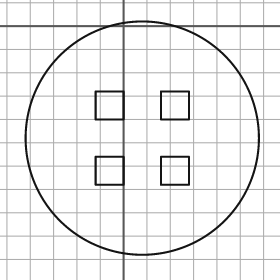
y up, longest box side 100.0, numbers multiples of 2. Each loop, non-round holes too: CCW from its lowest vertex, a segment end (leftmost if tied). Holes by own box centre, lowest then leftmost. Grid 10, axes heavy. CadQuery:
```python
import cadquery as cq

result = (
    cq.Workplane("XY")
    .moveTo(8.0, -48.0)
    .circle(50.0)
    .moveTo(-12.0, -68.0)
    .lineTo(0.0, -68.0)
    .lineTo(0.0, -56.0)
    .lineTo(-12.0, -56.0)
    .close()
    .moveTo(16.0, -68.0)
    .lineTo(28.0, -68.0)
    .lineTo(28.0, -56.0)
    .lineTo(16.0, -56.0)
    .close()
    .moveTo(-12.0, -40.0)
    .lineTo(0.0, -40.0)
    .lineTo(0.0, -28.0)
    .lineTo(-12.0, -28.0)
    .close()
    .moveTo(16.0, -40.0)
    .lineTo(28.0, -40.0)
    .lineTo(28.0, -28.0)
    .lineTo(16.0, -28.0)
    .close()
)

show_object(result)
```